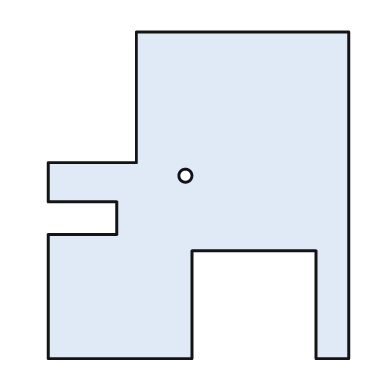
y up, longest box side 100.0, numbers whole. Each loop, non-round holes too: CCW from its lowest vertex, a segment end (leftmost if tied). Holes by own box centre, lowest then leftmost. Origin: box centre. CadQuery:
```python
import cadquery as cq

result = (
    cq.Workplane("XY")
    .moveTo(-46.0, -50.0)
    .lineTo(-2.0, -50.0)
    .lineTo(-2.0, -17.0)
    .lineTo(36.0, -17.0)
    .lineTo(36.0, -50.0)
    .lineTo(46.0, -50.0)
    .lineTo(46.0, 50.0)
    .lineTo(-19.0, 50.0)
    .lineTo(-19.0, 10.0)
    .lineTo(-46.0, 10.0)
    .lineTo(-46.0, -2.0)
    .lineTo(-25.0, -2.0)
    .lineTo(-25.0, -12.0)
    .lineTo(-46.0, -12.0)
    .close()
    .moveTo(-4.0, 6.0)
    .circle(2.0)
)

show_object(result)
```